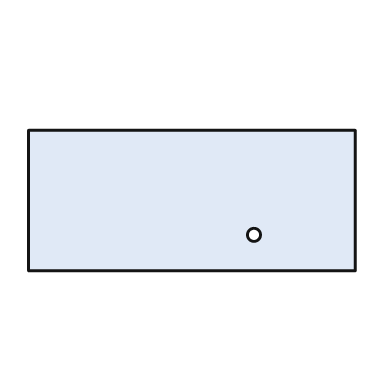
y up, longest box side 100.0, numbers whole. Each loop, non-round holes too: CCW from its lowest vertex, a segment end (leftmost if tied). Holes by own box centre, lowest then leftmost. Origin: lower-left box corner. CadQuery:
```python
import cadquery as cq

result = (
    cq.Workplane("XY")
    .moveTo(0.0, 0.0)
    .lineTo(100.0, 0.0)
    .lineTo(100.0, 43.0)
    .lineTo(0.0, 43.0)
    .close()
    .moveTo(69.0, 11.0)
    .circle(2.0)
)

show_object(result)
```